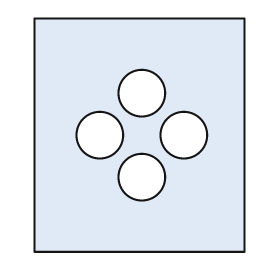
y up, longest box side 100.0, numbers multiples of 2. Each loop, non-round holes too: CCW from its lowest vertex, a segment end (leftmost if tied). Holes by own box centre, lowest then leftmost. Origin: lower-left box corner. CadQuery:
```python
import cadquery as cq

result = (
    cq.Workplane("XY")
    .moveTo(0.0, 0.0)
    .lineTo(90.0, 0.0)
    .lineTo(90.0, 100.0)
    .lineTo(0.0, 100.0)
    .close()
    .moveTo(46.0, 32.0)
    .circle(10.0)
    .moveTo(28.0, 50.0)
    .circle(10.0)
    .moveTo(64.0, 50.0)
    .circle(10.0)
    .moveTo(46.0, 68.0)
    .circle(10.0)
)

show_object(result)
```